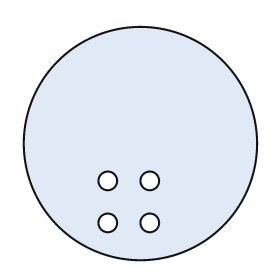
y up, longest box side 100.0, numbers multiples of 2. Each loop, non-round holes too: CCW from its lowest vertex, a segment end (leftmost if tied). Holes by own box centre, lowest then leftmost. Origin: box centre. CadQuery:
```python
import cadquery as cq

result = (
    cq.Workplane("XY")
    .moveTo(0.0, 0.0)
    .circle(50.0)
    .moveTo(-14.0, -34.0)
    .circle(4.0)
    .moveTo(4.0, -34.0)
    .circle(4.0)
    .moveTo(-14.0, -16.0)
    .circle(4.0)
    .moveTo(4.0, -16.0)
    .circle(4.0)
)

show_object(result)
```